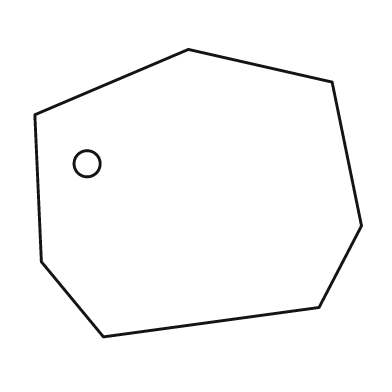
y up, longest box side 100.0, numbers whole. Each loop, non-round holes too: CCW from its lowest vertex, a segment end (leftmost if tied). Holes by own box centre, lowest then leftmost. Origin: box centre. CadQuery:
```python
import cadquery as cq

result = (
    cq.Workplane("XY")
    .moveTo(-29.0, -44.0)
    .lineTo(37.0, -35.0)
    .lineTo(50.0, -10.0)
    .lineTo(41.0, 34.0)
    .lineTo(-3.0, 44.0)
    .lineTo(-50.0, 24.0)
    .lineTo(-48.0, -21.0)
    .close()
    .moveTo(-34.0, 9.0)
    .circle(4.0)
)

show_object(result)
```